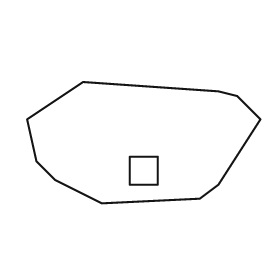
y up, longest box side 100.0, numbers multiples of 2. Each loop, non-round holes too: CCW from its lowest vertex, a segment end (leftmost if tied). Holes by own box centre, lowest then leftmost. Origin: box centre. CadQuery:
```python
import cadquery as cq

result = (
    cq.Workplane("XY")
    .moveTo(-18.0, -26.0)
    .lineTo(24.0, -24.0)
    .lineTo(32.0, -18.0)
    .lineTo(50.0, 10.0)
    .lineTo(40.0, 20.0)
    .lineTo(32.0, 22.0)
    .lineTo(-26.0, 26.0)
    .lineTo(-50.0, 10.0)
    .lineTo(-46.0, -8.0)
    .lineTo(-38.0, -16.0)
    .close()
    .moveTo(-6.0, -18.0)
    .lineTo(6.0, -18.0)
    .lineTo(6.0, -6.0)
    .lineTo(-6.0, -6.0)
    .close()
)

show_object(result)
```